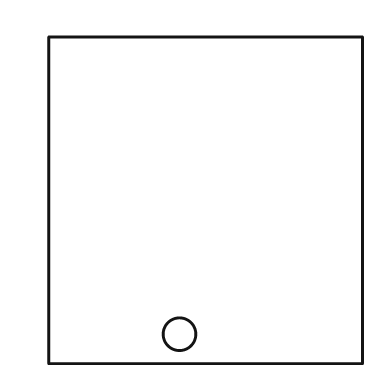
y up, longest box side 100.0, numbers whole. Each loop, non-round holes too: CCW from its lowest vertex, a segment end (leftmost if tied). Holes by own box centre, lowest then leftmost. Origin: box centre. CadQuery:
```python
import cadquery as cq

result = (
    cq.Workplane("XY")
    .moveTo(-48.0, -50.0)
    .lineTo(48.0, -50.0)
    .lineTo(48.0, 50.0)
    .lineTo(-48.0, 50.0)
    .close()
    .moveTo(-8.0, -41.0)
    .circle(5.0)
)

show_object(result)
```